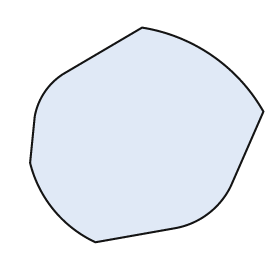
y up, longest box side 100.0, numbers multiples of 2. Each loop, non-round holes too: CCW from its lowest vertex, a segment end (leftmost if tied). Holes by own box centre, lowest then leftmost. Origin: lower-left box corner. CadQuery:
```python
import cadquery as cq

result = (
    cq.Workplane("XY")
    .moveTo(28.0, 0.0)
    .lineTo(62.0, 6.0)
    .threePointArc((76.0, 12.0), (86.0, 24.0))
    .lineTo(100.0, 56.0)
    .threePointArc((78.0, 80.0), (48.0, 92.0))
    .lineTo(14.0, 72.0)
    .threePointArc((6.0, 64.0), (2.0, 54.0))
    .lineTo(0.0, 34.0)
    .threePointArc((10.0, 14.0), (28.0, 0.0))
    .close()
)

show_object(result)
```